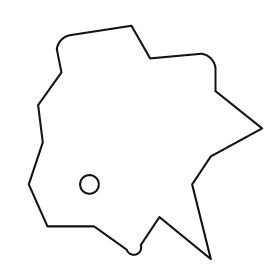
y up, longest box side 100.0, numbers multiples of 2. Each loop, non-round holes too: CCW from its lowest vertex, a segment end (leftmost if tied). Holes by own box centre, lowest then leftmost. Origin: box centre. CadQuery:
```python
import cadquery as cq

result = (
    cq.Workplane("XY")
    .moveTo(28.0, -50.0)
    .lineTo(20.0, -18.0)
    .lineTo(28.0, -6.0)
    .lineTo(50.0, 6.0)
    .lineTo(30.0, 22.0)
    .lineTo(30.0, 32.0)
    .threePointArc((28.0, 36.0), (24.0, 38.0))
    .lineTo(2.0, 36.0)
    .lineTo(-6.0, 50.0)
    .lineTo(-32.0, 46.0)
    .threePointArc((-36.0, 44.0), (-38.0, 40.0))
    .lineTo(-36.0, 30.0)
    .lineTo(-46.0, 16.0)
    .lineTo(-44.0, 0.0)
    .lineTo(-50.0, -18.0)
    .lineTo(-42.0, -36.0)
    .lineTo(-22.0, -36.0)
    .lineTo(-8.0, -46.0)
    .threePointArc((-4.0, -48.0), (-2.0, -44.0))
    .lineTo(6.0, -32.0)
    .close()
    .moveTo(-24.0, -18.0)
    .circle(4.0)
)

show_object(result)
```